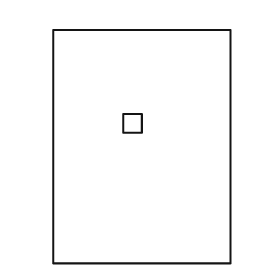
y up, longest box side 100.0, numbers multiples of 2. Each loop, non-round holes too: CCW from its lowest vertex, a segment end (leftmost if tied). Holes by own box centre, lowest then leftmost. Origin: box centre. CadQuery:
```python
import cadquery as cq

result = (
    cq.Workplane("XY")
    .moveTo(-38.0, -50.0)
    .lineTo(38.0, -50.0)
    .lineTo(38.0, 50.0)
    .lineTo(-38.0, 50.0)
    .close()
    .moveTo(-8.0, 6.0)
    .lineTo(0.0, 6.0)
    .lineTo(0.0, 14.0)
    .lineTo(-8.0, 14.0)
    .close()
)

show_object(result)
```